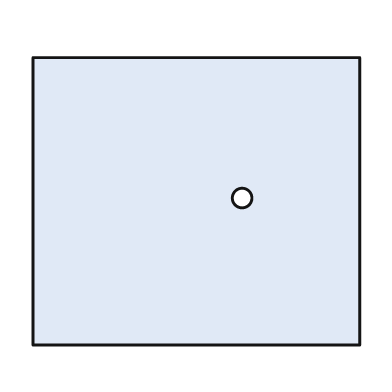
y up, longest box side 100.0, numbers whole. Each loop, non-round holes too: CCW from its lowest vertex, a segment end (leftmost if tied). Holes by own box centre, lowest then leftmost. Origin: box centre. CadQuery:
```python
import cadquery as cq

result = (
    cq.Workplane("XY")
    .moveTo(-50.0, -44.0)
    .lineTo(50.0, -44.0)
    .lineTo(50.0, 44.0)
    .lineTo(-50.0, 44.0)
    .close()
    .moveTo(14.0, 1.0)
    .circle(3.0)
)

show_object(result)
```